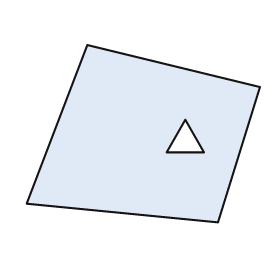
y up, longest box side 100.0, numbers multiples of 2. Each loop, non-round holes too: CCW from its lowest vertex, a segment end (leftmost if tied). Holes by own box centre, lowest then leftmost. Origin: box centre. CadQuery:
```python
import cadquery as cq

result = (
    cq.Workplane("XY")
    .moveTo(32.0, -38.0)
    .lineTo(50.0, 20.0)
    .lineTo(-24.0, 38.0)
    .lineTo(-50.0, -30.0)
    .close()
    .moveTo(10.0, -8.0)
    .lineTo(26.0, -8.0)
    .lineTo(18.0, 6.0)
    .close()
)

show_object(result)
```